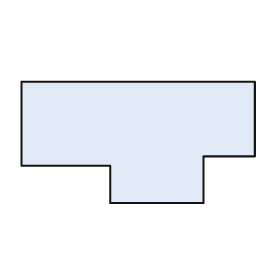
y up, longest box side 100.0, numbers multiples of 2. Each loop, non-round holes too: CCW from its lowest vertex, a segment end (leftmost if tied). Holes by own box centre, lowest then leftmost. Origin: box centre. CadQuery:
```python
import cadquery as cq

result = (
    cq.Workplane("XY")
    .moveTo(-12.0, -26.0)
    .lineTo(28.0, -26.0)
    .lineTo(28.0, -6.0)
    .lineTo(50.0, -6.0)
    .lineTo(50.0, 26.0)
    .lineTo(-50.0, 26.0)
    .lineTo(-50.0, -10.0)
    .lineTo(-12.0, -10.0)
    .close()
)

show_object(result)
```